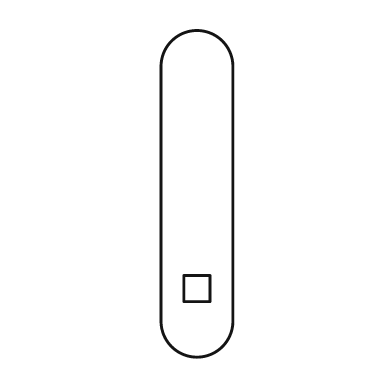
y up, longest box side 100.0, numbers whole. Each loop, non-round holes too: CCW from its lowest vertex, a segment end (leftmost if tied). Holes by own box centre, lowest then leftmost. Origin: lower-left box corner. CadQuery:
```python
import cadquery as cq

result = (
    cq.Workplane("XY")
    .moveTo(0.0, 11.0)
    .threePointArc((11.0, 0.0), (22.0, 11.0))
    .lineTo(22.0, 89.0)
    .threePointArc((11.0, 100.0), (0.0, 89.0))
    .close()
    .moveTo(7.0, 17.0)
    .lineTo(15.0, 17.0)
    .lineTo(15.0, 25.0)
    .lineTo(7.0, 25.0)
    .close()
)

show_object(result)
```